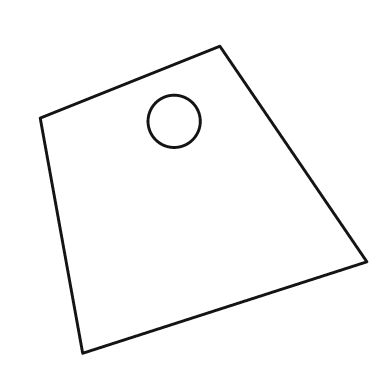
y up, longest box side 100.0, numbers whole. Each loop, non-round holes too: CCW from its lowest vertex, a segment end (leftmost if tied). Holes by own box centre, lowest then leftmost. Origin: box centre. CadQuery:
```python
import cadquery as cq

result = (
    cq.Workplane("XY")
    .moveTo(-37.0, -47.0)
    .lineTo(50.0, -19.0)
    .lineTo(5.0, 47.0)
    .lineTo(-50.0, 25.0)
    .close()
    .moveTo(-9.0, 24.0)
    .circle(8.0)
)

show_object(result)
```